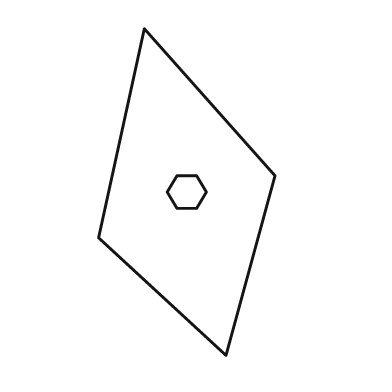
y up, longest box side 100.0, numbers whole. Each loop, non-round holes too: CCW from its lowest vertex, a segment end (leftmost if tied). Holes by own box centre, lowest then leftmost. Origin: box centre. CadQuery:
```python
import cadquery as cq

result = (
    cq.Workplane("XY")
    .moveTo(12.0, -50.0)
    .lineTo(27.0, 5.0)
    .lineTo(-13.0, 50.0)
    .lineTo(-27.0, -14.0)
    .close()
    .moveTo(-3.0, -5.0)
    .lineTo(3.0, -5.0)
    .lineTo(6.0, 0.0)
    .lineTo(3.0, 5.0)
    .lineTo(-3.0, 5.0)
    .lineTo(-6.0, 0.0)
    .close()
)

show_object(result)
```